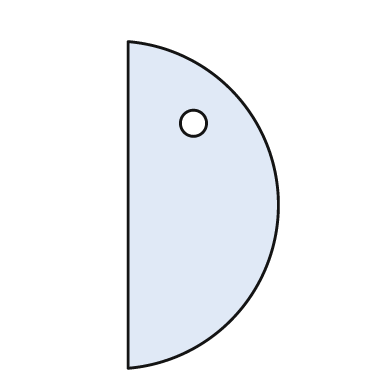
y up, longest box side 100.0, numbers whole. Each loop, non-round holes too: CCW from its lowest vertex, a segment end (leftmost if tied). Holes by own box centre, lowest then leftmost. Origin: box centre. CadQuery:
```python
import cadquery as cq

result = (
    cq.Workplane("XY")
    .moveTo(-23.0, -50.0)
    .threePointArc((23.0, 0.0), (-23.0, 50.0))
    .close()
    .moveTo(-3.0, 25.0)
    .circle(4.0)
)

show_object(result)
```